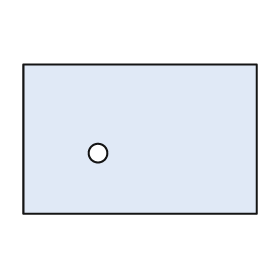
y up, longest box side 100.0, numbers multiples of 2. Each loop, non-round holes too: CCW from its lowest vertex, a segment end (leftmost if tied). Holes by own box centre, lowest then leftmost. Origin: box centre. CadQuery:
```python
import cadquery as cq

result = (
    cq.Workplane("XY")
    .moveTo(-50.0, -32.0)
    .lineTo(50.0, -32.0)
    .lineTo(50.0, 32.0)
    .lineTo(-50.0, 32.0)
    .close()
    .moveTo(-18.0, -6.0)
    .circle(4.0)
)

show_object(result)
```